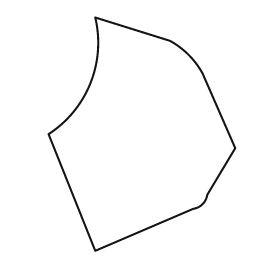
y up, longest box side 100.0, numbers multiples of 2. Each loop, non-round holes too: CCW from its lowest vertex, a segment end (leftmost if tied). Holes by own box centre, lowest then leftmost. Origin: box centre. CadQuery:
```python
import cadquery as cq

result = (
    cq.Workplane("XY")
    .moveTo(-20.0, -50.0)
    .lineTo(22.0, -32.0)
    .threePointArc((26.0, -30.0), (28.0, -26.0))
    .lineTo(40.0, -6.0)
    .lineTo(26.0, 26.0)
    .threePointArc((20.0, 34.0), (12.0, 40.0))
    .lineTo(-20.0, 50.0)
    .threePointArc((-22.0, 22.0), (-40.0, 0.0))
    .close()
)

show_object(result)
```